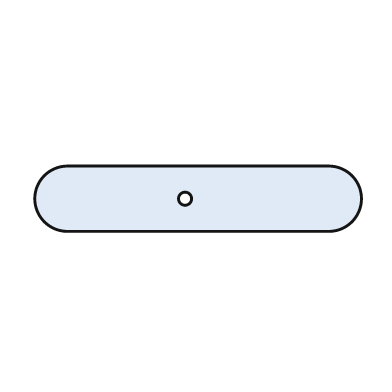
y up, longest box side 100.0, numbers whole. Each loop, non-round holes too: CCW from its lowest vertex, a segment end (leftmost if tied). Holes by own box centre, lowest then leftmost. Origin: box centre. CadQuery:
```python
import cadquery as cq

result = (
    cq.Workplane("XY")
    .moveTo(-40.0, -10.0)
    .lineTo(40.0, -10.0)
    .threePointArc((50.0, 0.0), (40.0, 10.0))
    .lineTo(-40.0, 10.0)
    .threePointArc((-50.0, 0.0), (-40.0, -10.0))
    .close()
    .moveTo(-4.0, 0.0)
    .circle(2.0)
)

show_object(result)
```